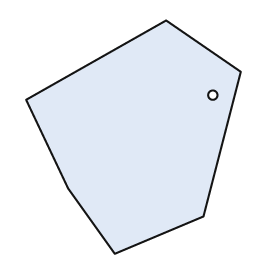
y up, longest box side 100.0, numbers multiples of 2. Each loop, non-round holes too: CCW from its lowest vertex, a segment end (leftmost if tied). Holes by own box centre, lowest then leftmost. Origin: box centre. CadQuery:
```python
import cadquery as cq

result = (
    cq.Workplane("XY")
    .moveTo(-8.0, -50.0)
    .lineTo(30.0, -34.0)
    .lineTo(46.0, 28.0)
    .lineTo(14.0, 50.0)
    .lineTo(-46.0, 16.0)
    .lineTo(-28.0, -22.0)
    .close()
    .moveTo(34.0, 18.0)
    .circle(2.0)
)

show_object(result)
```